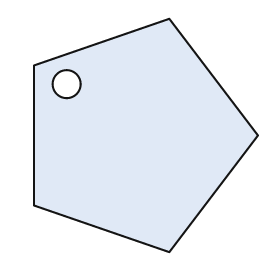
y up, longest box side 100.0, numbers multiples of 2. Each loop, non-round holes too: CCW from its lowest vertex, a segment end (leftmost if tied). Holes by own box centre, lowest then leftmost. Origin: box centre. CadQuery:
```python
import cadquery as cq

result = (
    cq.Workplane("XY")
    .moveTo(10.0, -50.0)
    .lineTo(48.0, 0.0)
    .lineTo(10.0, 50.0)
    .lineTo(-48.0, 30.0)
    .lineTo(-48.0, -30.0)
    .close()
    .moveTo(-34.0, 22.0)
    .circle(6.0)
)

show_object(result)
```